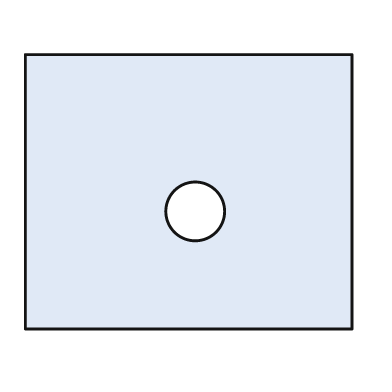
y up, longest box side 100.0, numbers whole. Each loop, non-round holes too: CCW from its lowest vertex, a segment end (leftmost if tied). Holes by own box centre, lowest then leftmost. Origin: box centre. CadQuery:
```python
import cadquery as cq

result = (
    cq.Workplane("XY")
    .moveTo(-50.0, -42.0)
    .lineTo(50.0, -42.0)
    .lineTo(50.0, 42.0)
    .lineTo(-50.0, 42.0)
    .close()
    .moveTo(2.0, -6.0)
    .circle(9.0)
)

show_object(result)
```